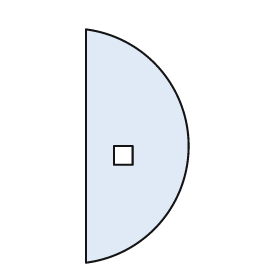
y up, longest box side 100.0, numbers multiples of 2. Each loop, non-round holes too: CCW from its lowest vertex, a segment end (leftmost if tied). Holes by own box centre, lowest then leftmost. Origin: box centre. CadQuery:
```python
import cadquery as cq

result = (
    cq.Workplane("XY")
    .moveTo(-22.0, -50.0)
    .threePointArc((22.0, 0.0), (-22.0, 50.0))
    .close()
    .moveTo(-10.0, -8.0)
    .lineTo(-2.0, -8.0)
    .lineTo(-2.0, 0.0)
    .lineTo(-10.0, 0.0)
    .close()
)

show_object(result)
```